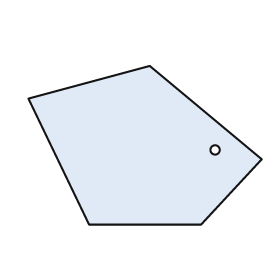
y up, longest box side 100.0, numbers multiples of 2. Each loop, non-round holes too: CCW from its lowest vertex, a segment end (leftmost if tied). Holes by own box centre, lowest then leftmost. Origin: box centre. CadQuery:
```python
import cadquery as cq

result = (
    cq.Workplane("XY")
    .moveTo(-24.0, -34.0)
    .lineTo(24.0, -34.0)
    .lineTo(50.0, -6.0)
    .lineTo(2.0, 34.0)
    .lineTo(-50.0, 20.0)
    .close()
    .moveTo(30.0, -2.0)
    .circle(2.0)
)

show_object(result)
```